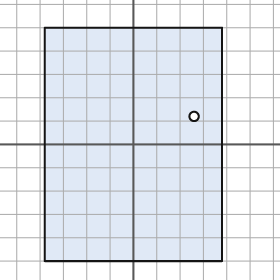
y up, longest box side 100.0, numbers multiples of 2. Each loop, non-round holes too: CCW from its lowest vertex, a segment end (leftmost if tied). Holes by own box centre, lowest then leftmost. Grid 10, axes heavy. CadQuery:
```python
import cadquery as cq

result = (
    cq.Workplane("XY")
    .moveTo(-38.0, -50.0)
    .lineTo(38.0, -50.0)
    .lineTo(38.0, 50.0)
    .lineTo(-38.0, 50.0)
    .close()
    .moveTo(26.0, 12.0)
    .circle(2.0)
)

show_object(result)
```